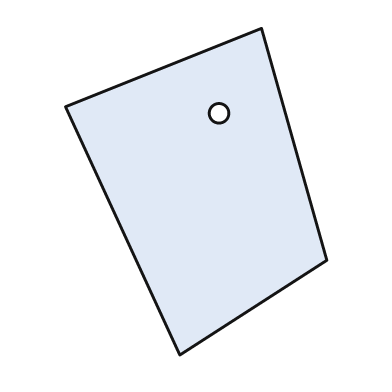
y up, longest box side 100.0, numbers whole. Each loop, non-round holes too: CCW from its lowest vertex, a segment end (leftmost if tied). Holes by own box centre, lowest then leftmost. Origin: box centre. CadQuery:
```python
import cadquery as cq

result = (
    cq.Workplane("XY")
    .moveTo(-5.0, -50.0)
    .lineTo(40.0, -21.0)
    .lineTo(20.0, 50.0)
    .lineTo(-40.0, 26.0)
    .close()
    .moveTo(7.0, 24.0)
    .circle(3.0)
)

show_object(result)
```